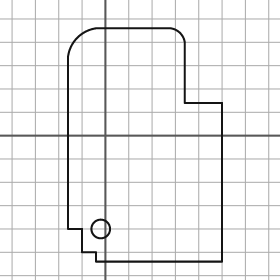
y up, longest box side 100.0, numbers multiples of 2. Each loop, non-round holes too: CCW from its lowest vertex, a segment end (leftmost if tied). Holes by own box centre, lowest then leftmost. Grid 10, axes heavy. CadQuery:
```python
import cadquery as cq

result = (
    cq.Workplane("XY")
    .moveTo(-4.0, -54.0)
    .lineTo(50.0, -54.0)
    .lineTo(50.0, 14.0)
    .lineTo(34.0, 14.0)
    .lineTo(34.0, 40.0)
    .threePointArc((32.0, 44.0), (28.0, 46.0))
    .lineTo(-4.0, 46.0)
    .threePointArc((-12.0, 42.0), (-16.0, 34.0))
    .lineTo(-16.0, -40.0)
    .lineTo(-10.0, -40.0)
    .lineTo(-10.0, -50.0)
    .lineTo(-4.0, -50.0)
    .close()
    .moveTo(-2.0, -40.0)
    .circle(4.0)
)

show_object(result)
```